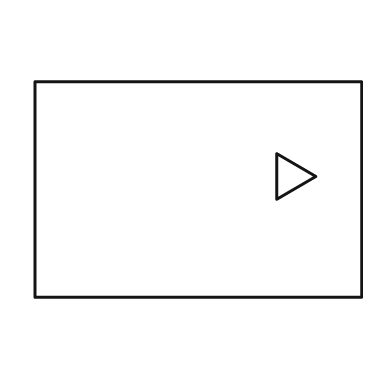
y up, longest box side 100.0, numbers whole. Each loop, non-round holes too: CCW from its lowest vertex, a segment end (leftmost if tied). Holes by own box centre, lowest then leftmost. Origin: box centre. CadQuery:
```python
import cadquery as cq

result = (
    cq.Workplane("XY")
    .moveTo(-50.0, -33.0)
    .lineTo(50.0, -33.0)
    .lineTo(50.0, 33.0)
    .lineTo(-50.0, 33.0)
    .close()
    .moveTo(24.0, -3.0)
    .lineTo(36.0, 4.0)
    .lineTo(24.0, 11.0)
    .close()
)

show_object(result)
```